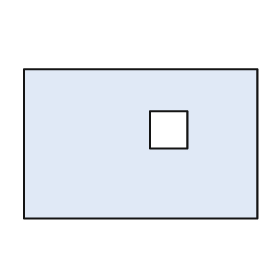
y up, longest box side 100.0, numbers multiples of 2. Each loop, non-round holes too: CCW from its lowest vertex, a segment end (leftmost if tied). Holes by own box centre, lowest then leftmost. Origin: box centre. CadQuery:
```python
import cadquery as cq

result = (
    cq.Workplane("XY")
    .moveTo(-50.0, -32.0)
    .lineTo(50.0, -32.0)
    .lineTo(50.0, 32.0)
    .lineTo(-50.0, 32.0)
    .close()
    .moveTo(4.0, -2.0)
    .lineTo(20.0, -2.0)
    .lineTo(20.0, 14.0)
    .lineTo(4.0, 14.0)
    .close()
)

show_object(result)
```